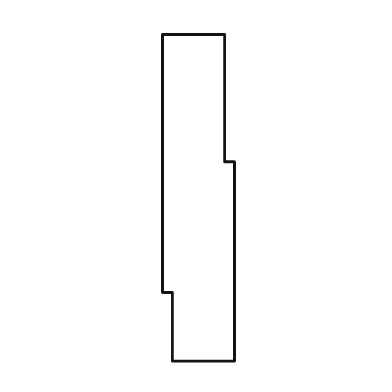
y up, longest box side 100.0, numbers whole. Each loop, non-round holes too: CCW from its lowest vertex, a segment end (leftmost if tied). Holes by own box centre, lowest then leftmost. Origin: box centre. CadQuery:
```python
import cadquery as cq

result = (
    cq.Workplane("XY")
    .moveTo(-8.0, -50.0)
    .lineTo(11.0, -50.0)
    .lineTo(11.0, 11.0)
    .lineTo(8.0, 11.0)
    .lineTo(8.0, 50.0)
    .lineTo(-11.0, 50.0)
    .lineTo(-11.0, -29.0)
    .lineTo(-8.0, -29.0)
    .close()
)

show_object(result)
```